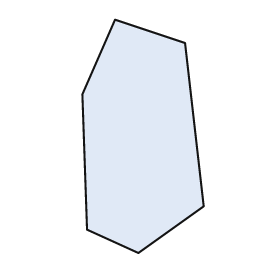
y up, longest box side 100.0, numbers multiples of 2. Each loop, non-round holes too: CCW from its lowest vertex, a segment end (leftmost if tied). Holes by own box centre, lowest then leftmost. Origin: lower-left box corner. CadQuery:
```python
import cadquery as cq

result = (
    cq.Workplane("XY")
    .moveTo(24.0, 0.0)
    .lineTo(52.0, 20.0)
    .lineTo(44.0, 90.0)
    .lineTo(14.0, 100.0)
    .lineTo(0.0, 68.0)
    .lineTo(2.0, 10.0)
    .close()
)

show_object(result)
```